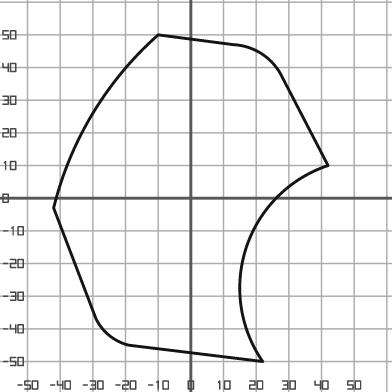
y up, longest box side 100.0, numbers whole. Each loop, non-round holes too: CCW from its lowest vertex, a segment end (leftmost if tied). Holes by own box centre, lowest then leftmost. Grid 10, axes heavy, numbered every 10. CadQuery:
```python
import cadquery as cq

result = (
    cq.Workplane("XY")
    .moveTo(22.0, -50.0)
    .threePointArc((17.0, -15.0), (42.0, 10.0))
    .lineTo(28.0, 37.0)
    .threePointArc((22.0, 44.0), (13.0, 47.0))
    .lineTo(-10.0, 50.0)
    .threePointArc((-30.0, 26.0), (-42.0, -3.0))
    .lineTo(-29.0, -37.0)
    .threePointArc((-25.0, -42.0), (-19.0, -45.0))
    .close()
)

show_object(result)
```